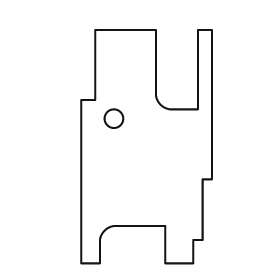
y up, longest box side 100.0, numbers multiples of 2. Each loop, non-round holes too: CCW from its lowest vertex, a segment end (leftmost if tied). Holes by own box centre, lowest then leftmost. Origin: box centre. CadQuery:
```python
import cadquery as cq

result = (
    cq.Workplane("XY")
    .moveTo(-28.0, -50.0)
    .lineTo(-20.0, -50.0)
    .lineTo(-20.0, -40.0)
    .threePointArc((-18.0, -36.0), (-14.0, -34.0))
    .lineTo(8.0, -34.0)
    .lineTo(8.0, -50.0)
    .lineTo(20.0, -50.0)
    .lineTo(20.0, -40.0)
    .lineTo(24.0, -40.0)
    .lineTo(24.0, -14.0)
    .lineTo(28.0, -14.0)
    .lineTo(28.0, 50.0)
    .lineTo(22.0, 50.0)
    .lineTo(22.0, 16.0)
    .lineTo(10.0, 16.0)
    .threePointArc((6.0, 18.0), (4.0, 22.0))
    .lineTo(4.0, 50.0)
    .lineTo(-22.0, 50.0)
    .lineTo(-22.0, 20.0)
    .lineTo(-28.0, 20.0)
    .close()
    .moveTo(-14.0, 12.0)
    .circle(4.0)
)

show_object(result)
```